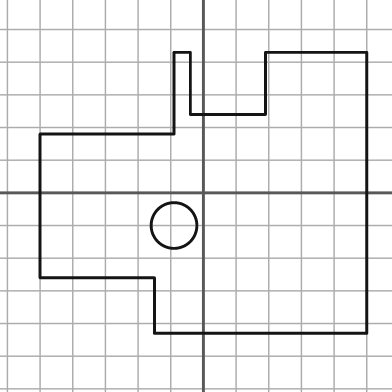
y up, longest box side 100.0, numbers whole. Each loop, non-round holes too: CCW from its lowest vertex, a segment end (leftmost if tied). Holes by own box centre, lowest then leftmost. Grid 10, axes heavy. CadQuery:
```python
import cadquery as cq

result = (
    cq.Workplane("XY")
    .moveTo(-15.0, -43.0)
    .lineTo(50.0, -43.0)
    .lineTo(50.0, 43.0)
    .lineTo(19.0, 43.0)
    .lineTo(19.0, 24.0)
    .lineTo(-4.0, 24.0)
    .lineTo(-4.0, 43.0)
    .lineTo(-9.0, 43.0)
    .lineTo(-9.0, 18.0)
    .lineTo(-50.0, 18.0)
    .lineTo(-50.0, -26.0)
    .lineTo(-15.0, -26.0)
    .close()
    .moveTo(-9.0, -10.0)
    .circle(7.0)
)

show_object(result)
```